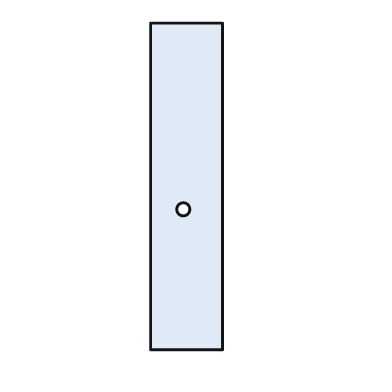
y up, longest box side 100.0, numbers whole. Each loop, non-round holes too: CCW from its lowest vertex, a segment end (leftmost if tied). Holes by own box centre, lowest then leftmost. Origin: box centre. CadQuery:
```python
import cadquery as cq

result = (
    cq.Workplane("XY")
    .moveTo(-11.0, -50.0)
    .lineTo(11.0, -50.0)
    .lineTo(11.0, 50.0)
    .lineTo(-11.0, 50.0)
    .close()
    .moveTo(-1.0, -7.0)
    .circle(2.0)
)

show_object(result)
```